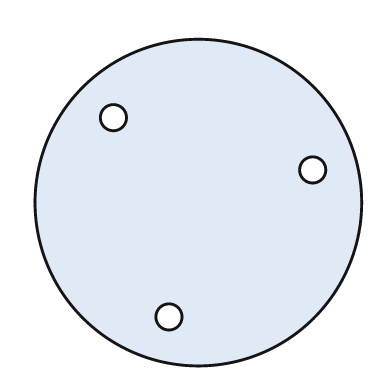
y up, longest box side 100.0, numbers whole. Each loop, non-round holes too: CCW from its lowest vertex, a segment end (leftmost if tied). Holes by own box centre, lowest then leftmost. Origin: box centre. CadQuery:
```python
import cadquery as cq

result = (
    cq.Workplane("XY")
    .moveTo(0.0, 0.0)
    .circle(50.0)
    .moveTo(-9.0, -35.0)
    .circle(4.0)
    .moveTo(35.0, 10.0)
    .circle(4.0)
    .moveTo(-26.0, 26.0)
    .circle(4.0)
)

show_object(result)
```